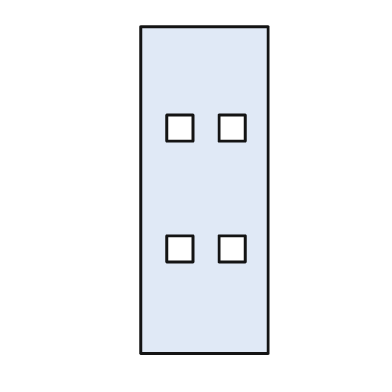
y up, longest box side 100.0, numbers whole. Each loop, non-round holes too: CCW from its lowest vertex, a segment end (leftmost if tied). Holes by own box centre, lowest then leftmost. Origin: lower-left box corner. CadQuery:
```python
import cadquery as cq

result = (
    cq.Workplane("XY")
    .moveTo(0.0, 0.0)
    .lineTo(39.0, 0.0)
    .lineTo(39.0, 100.0)
    .lineTo(0.0, 100.0)
    .close()
    .moveTo(8.0, 28.0)
    .lineTo(16.0, 28.0)
    .lineTo(16.0, 36.0)
    .lineTo(8.0, 36.0)
    .close()
    .moveTo(24.0, 28.0)
    .lineTo(32.0, 28.0)
    .lineTo(32.0, 36.0)
    .lineTo(24.0, 36.0)
    .close()
    .moveTo(8.0, 65.0)
    .lineTo(16.0, 65.0)
    .lineTo(16.0, 73.0)
    .lineTo(8.0, 73.0)
    .close()
    .moveTo(24.0, 65.0)
    .lineTo(32.0, 65.0)
    .lineTo(32.0, 73.0)
    .lineTo(24.0, 73.0)
    .close()
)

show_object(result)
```